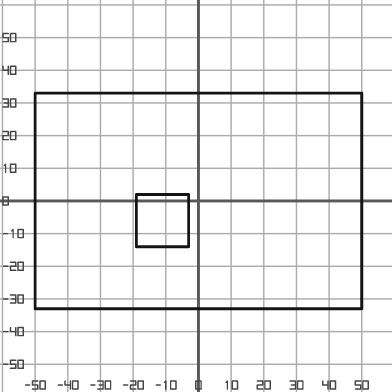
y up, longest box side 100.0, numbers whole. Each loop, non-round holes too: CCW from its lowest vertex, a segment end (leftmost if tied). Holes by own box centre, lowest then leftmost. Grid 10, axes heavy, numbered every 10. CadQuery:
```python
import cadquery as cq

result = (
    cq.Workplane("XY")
    .moveTo(-50.0, -33.0)
    .lineTo(50.0, -33.0)
    .lineTo(50.0, 33.0)
    .lineTo(-50.0, 33.0)
    .close()
    .moveTo(-19.0, -14.0)
    .lineTo(-3.0, -14.0)
    .lineTo(-3.0, 2.0)
    .lineTo(-19.0, 2.0)
    .close()
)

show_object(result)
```